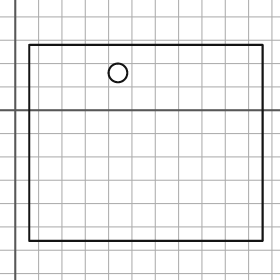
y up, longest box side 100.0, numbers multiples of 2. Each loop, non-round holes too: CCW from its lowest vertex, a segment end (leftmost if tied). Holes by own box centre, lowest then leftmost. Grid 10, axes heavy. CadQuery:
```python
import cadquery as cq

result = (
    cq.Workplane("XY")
    .moveTo(6.0, -56.0)
    .lineTo(106.0, -56.0)
    .lineTo(106.0, 28.0)
    .lineTo(6.0, 28.0)
    .close()
    .moveTo(44.0, 16.0)
    .circle(4.0)
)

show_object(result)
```